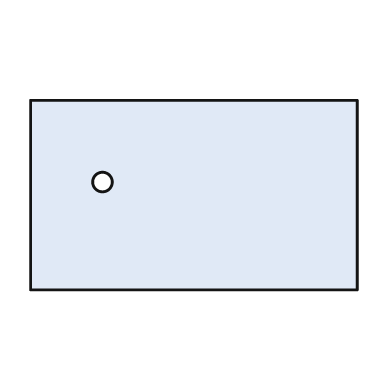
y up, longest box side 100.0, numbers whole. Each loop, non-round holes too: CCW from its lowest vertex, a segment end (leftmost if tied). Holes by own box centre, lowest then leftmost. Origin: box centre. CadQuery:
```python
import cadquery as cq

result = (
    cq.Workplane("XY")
    .moveTo(-50.0, -29.0)
    .lineTo(50.0, -29.0)
    .lineTo(50.0, 29.0)
    .lineTo(-50.0, 29.0)
    .close()
    .moveTo(-28.0, 4.0)
    .circle(3.0)
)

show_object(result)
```